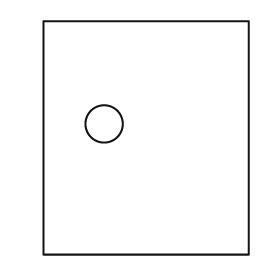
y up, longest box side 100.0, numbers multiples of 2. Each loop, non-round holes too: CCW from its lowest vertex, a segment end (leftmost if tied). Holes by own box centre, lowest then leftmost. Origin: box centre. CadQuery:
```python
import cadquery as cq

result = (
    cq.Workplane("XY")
    .moveTo(-44.0, -50.0)
    .lineTo(44.0, -50.0)
    .lineTo(44.0, 50.0)
    .lineTo(-44.0, 50.0)
    .close()
    .moveTo(-18.0, 6.0)
    .circle(8.0)
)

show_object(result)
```